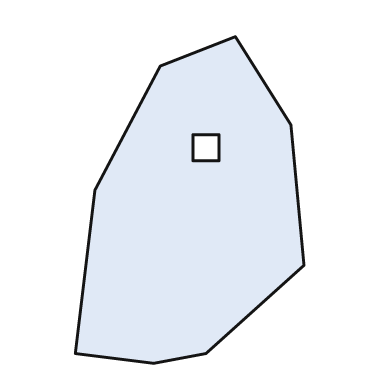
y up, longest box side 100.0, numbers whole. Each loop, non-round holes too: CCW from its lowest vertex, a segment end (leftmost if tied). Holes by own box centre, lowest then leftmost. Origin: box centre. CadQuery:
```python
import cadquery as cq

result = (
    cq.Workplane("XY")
    .moveTo(-11.0, -50.0)
    .lineTo(5.0, -47.0)
    .lineTo(35.0, -20.0)
    .lineTo(31.0, 23.0)
    .lineTo(14.0, 50.0)
    .lineTo(-9.0, 41.0)
    .lineTo(-29.0, 3.0)
    .lineTo(-35.0, -47.0)
    .close()
    .moveTo(1.0, 12.0)
    .lineTo(9.0, 12.0)
    .lineTo(9.0, 20.0)
    .lineTo(1.0, 20.0)
    .close()
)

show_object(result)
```